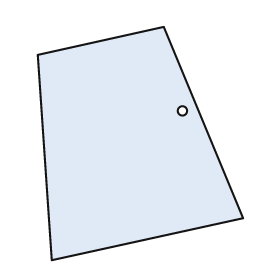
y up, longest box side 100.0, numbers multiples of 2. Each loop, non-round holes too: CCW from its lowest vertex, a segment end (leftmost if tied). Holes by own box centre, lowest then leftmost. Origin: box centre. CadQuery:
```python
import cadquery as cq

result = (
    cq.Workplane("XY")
    .moveTo(-38.0, -50.0)
    .lineTo(44.0, -32.0)
    .lineTo(10.0, 50.0)
    .lineTo(-44.0, 38.0)
    .close()
    .moveTo(18.0, 14.0)
    .circle(2.0)
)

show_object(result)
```